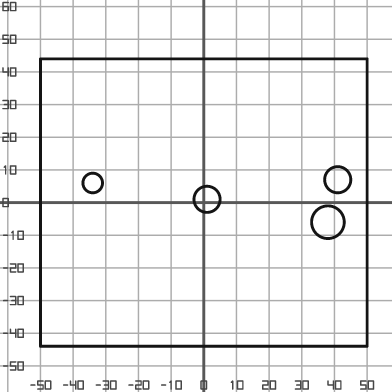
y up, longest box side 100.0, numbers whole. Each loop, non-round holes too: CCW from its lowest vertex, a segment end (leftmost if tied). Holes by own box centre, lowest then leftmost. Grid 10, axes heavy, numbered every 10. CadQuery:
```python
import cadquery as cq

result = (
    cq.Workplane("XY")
    .moveTo(-50.0, -44.0)
    .lineTo(50.0, -44.0)
    .lineTo(50.0, 44.0)
    .lineTo(-50.0, 44.0)
    .close()
    .moveTo(38.0, -6.0)
    .circle(5.0)
    .moveTo(1.0, 1.0)
    .circle(4.0)
    .moveTo(-34.0, 6.0)
    .circle(3.0)
    .moveTo(41.0, 7.0)
    .circle(4.0)
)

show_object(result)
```